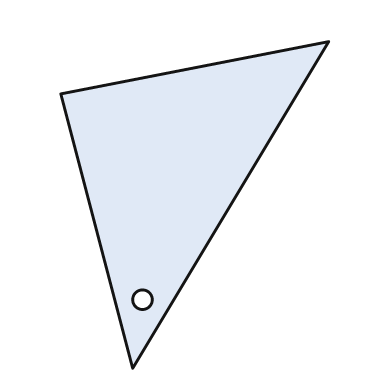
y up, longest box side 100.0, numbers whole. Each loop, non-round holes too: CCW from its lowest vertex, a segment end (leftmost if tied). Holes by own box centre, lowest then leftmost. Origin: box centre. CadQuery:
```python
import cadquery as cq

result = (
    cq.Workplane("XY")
    .moveTo(-19.0, -50.0)
    .lineTo(41.0, 50.0)
    .lineTo(-41.0, 34.0)
    .close()
    .moveTo(-16.0, -29.0)
    .circle(3.0)
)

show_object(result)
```